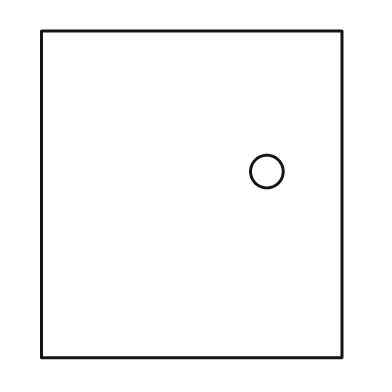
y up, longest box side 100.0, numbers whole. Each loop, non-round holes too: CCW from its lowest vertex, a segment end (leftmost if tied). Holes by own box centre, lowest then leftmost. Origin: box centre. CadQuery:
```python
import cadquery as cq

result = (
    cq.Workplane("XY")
    .moveTo(-46.0, -50.0)
    .lineTo(46.0, -50.0)
    .lineTo(46.0, 50.0)
    .lineTo(-46.0, 50.0)
    .close()
    .moveTo(23.0, 7.0)
    .circle(5.0)
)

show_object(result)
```